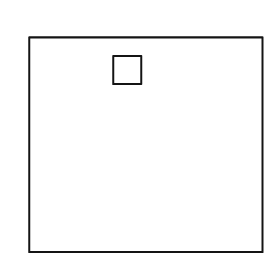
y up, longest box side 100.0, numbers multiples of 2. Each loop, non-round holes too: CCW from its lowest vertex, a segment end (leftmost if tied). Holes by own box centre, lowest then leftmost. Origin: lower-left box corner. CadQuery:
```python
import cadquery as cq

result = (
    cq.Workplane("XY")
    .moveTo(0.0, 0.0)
    .lineTo(100.0, 0.0)
    .lineTo(100.0, 92.0)
    .lineTo(0.0, 92.0)
    .close()
    .moveTo(36.0, 72.0)
    .lineTo(48.0, 72.0)
    .lineTo(48.0, 84.0)
    .lineTo(36.0, 84.0)
    .close()
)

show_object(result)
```